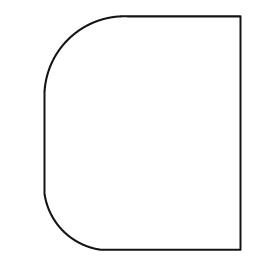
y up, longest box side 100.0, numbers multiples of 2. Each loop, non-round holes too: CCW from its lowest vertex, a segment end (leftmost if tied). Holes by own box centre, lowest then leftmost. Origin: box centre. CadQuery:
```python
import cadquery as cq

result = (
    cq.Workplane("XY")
    .moveTo(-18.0, -50.0)
    .lineTo(42.0, -50.0)
    .lineTo(42.0, 50.0)
    .lineTo(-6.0, 50.0)
    .threePointArc((-32.0, 40.0), (-42.0, 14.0))
    .lineTo(-42.0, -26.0)
    .threePointArc((-34.0, -42.0), (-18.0, -50.0))
    .close()
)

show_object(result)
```